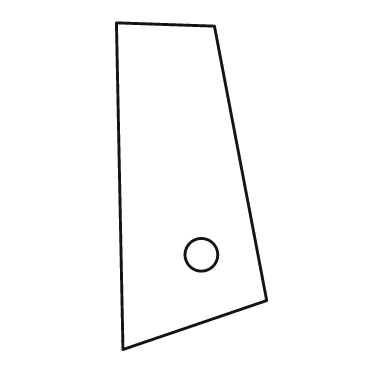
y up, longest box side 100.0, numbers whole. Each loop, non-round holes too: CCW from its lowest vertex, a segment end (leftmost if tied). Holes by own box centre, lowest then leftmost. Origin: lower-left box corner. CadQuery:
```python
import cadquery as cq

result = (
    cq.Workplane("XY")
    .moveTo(2.0, 0.0)
    .lineTo(46.0, 15.0)
    .lineTo(30.0, 99.0)
    .lineTo(0.0, 100.0)
    .close()
    .moveTo(26.0, 29.0)
    .circle(5.0)
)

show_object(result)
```